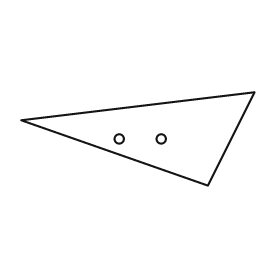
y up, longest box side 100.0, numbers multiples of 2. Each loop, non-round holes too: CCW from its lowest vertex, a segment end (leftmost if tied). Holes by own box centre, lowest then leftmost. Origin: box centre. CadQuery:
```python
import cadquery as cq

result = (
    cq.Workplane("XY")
    .moveTo(30.0, -20.0)
    .lineTo(50.0, 20.0)
    .lineTo(-50.0, 8.0)
    .close()
    .moveTo(-8.0, 0.0)
    .circle(2.0)
    .moveTo(10.0, 0.0)
    .circle(2.0)
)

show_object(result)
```